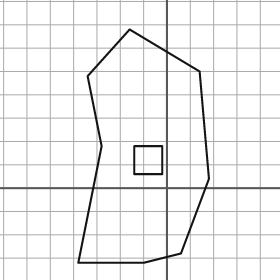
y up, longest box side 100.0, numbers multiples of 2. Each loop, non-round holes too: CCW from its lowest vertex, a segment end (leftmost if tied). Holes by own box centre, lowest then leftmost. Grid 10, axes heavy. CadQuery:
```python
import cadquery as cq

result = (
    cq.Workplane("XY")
    .moveTo(-38.0, -32.0)
    .lineTo(-10.0, -32.0)
    .lineTo(6.0, -28.0)
    .lineTo(18.0, 4.0)
    .lineTo(14.0, 50.0)
    .lineTo(-16.0, 68.0)
    .lineTo(-34.0, 48.0)
    .lineTo(-28.0, 18.0)
    .close()
    .moveTo(-14.0, 6.0)
    .lineTo(-2.0, 6.0)
    .lineTo(-2.0, 18.0)
    .lineTo(-14.0, 18.0)
    .close()
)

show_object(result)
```